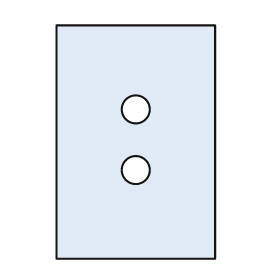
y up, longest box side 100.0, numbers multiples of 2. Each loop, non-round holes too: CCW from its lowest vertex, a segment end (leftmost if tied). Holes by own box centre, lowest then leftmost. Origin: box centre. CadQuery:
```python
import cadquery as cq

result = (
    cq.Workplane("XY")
    .moveTo(-34.0, -50.0)
    .lineTo(34.0, -50.0)
    .lineTo(34.0, 50.0)
    .lineTo(-34.0, 50.0)
    .close()
    .moveTo(0.0, -12.0)
    .circle(6.0)
    .moveTo(0.0, 14.0)
    .circle(6.0)
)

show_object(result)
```